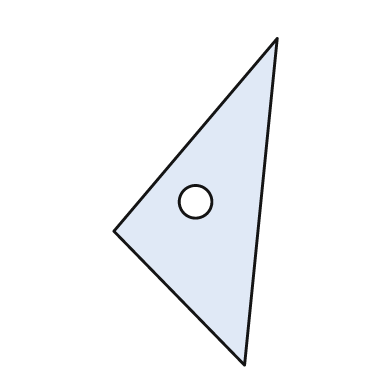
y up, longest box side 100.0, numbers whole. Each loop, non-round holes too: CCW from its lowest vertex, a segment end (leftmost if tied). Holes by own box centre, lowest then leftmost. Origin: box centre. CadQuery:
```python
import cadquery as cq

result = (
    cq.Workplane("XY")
    .moveTo(15.0, -50.0)
    .lineTo(25.0, 50.0)
    .lineTo(-25.0, -9.0)
    .close()
    .moveTo(0.0, 0.0)
    .circle(5.0)
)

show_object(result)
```